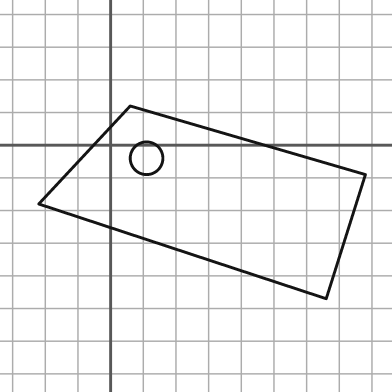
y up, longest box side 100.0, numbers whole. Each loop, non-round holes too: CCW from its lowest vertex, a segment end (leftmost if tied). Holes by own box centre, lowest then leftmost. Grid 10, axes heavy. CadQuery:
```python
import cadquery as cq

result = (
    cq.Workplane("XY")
    .moveTo(66.0, -47.0)
    .lineTo(78.0, -9.0)
    .lineTo(6.0, 12.0)
    .lineTo(-22.0, -18.0)
    .close()
    .moveTo(11.0, -4.0)
    .circle(5.0)
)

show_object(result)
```